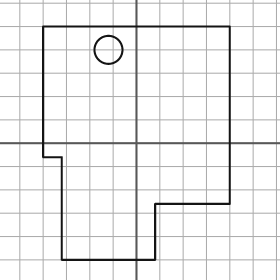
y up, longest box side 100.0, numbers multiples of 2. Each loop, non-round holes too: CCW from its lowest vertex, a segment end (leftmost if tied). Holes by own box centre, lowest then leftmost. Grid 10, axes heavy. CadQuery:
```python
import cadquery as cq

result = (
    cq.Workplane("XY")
    .moveTo(-32.0, -50.0)
    .lineTo(8.0, -50.0)
    .lineTo(8.0, -26.0)
    .lineTo(40.0, -26.0)
    .lineTo(40.0, 50.0)
    .lineTo(-40.0, 50.0)
    .lineTo(-40.0, -6.0)
    .lineTo(-32.0, -6.0)
    .close()
    .moveTo(-12.0, 40.0)
    .circle(6.0)
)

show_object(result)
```